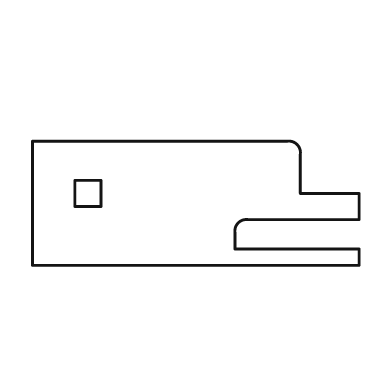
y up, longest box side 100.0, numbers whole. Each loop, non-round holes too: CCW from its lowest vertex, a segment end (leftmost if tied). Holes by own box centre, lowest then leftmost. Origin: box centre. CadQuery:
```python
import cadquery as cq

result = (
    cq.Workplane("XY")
    .moveTo(-50.0, -19.0)
    .lineTo(50.0, -19.0)
    .lineTo(50.0, -14.0)
    .lineTo(12.0, -14.0)
    .lineTo(12.0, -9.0)
    .threePointArc((13.0, -6.0), (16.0, -5.0))
    .lineTo(50.0, -5.0)
    .lineTo(50.0, 3.0)
    .lineTo(32.0, 3.0)
    .lineTo(32.0, 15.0)
    .threePointArc((31.0, 18.0), (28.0, 19.0))
    .lineTo(-50.0, 19.0)
    .close()
    .moveTo(-37.0, -1.0)
    .lineTo(-29.0, -1.0)
    .lineTo(-29.0, 7.0)
    .lineTo(-37.0, 7.0)
    .close()
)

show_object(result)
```